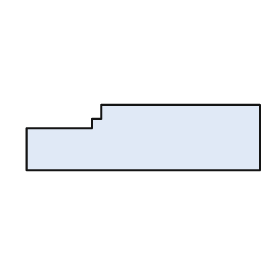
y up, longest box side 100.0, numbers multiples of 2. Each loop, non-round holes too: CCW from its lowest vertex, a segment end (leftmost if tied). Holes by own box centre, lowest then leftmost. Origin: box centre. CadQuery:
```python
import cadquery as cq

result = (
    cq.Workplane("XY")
    .moveTo(-50.0, -14.0)
    .lineTo(50.0, -14.0)
    .lineTo(50.0, 14.0)
    .lineTo(-18.0, 14.0)
    .lineTo(-18.0, 8.0)
    .lineTo(-22.0, 8.0)
    .lineTo(-22.0, 4.0)
    .lineTo(-50.0, 4.0)
    .close()
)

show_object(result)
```